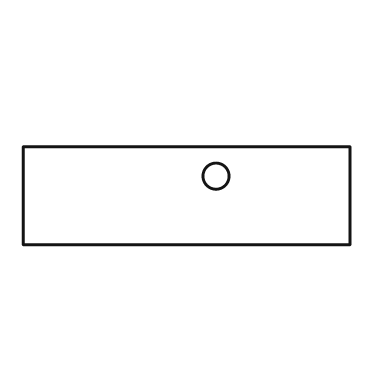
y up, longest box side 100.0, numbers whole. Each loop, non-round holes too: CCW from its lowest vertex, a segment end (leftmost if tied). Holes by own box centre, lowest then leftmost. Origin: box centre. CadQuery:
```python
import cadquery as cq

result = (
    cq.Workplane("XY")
    .moveTo(-50.0, -15.0)
    .lineTo(50.0, -15.0)
    .lineTo(50.0, 15.0)
    .lineTo(-50.0, 15.0)
    .close()
    .moveTo(9.0, 6.0)
    .circle(4.0)
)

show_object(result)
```